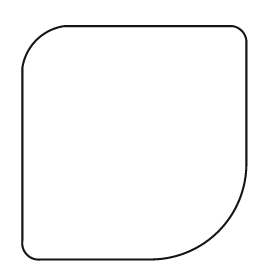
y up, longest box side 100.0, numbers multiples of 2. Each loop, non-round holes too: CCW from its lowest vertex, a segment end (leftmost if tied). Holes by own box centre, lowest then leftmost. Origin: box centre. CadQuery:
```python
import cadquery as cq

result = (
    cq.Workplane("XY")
    .moveTo(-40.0, -50.0)
    .lineTo(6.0, -50.0)
    .threePointArc((36.0, -38.0), (48.0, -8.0))
    .lineTo(48.0, 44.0)
    .threePointArc((46.0, 48.0), (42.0, 50.0))
    .lineTo(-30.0, 50.0)
    .threePointArc((-42.0, 44.0), (-48.0, 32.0))
    .lineTo(-48.0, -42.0)
    .threePointArc((-46.0, -48.0), (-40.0, -50.0))
    .close()
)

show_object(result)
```